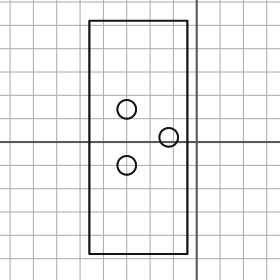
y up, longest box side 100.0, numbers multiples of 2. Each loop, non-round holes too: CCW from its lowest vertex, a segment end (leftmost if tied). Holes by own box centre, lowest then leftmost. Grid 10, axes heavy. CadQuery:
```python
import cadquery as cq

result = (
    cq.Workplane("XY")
    .moveTo(-46.0, -48.0)
    .lineTo(-4.0, -48.0)
    .lineTo(-4.0, 52.0)
    .lineTo(-46.0, 52.0)
    .close()
    .moveTo(-30.0, -10.0)
    .circle(4.0)
    .moveTo(-12.0, 2.0)
    .circle(4.0)
    .moveTo(-30.0, 14.0)
    .circle(4.0)
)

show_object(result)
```